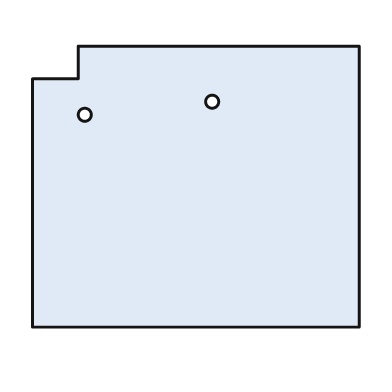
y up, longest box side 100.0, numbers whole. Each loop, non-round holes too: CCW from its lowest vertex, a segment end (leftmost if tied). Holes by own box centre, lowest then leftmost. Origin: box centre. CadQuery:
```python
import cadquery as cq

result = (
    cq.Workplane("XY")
    .moveTo(-50.0, -43.0)
    .lineTo(50.0, -43.0)
    .lineTo(50.0, 43.0)
    .lineTo(-36.0, 43.0)
    .lineTo(-36.0, 33.0)
    .lineTo(-50.0, 33.0)
    .close()
    .moveTo(-34.0, 22.0)
    .circle(2.0)
    .moveTo(5.0, 26.0)
    .circle(2.0)
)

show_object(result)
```